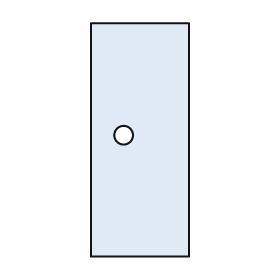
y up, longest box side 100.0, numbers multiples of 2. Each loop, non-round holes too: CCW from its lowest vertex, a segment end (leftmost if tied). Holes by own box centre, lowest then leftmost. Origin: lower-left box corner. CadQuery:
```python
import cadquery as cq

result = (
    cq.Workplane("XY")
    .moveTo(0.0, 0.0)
    .lineTo(42.0, 0.0)
    .lineTo(42.0, 100.0)
    .lineTo(0.0, 100.0)
    .close()
    .moveTo(14.0, 52.0)
    .circle(4.0)
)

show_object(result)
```